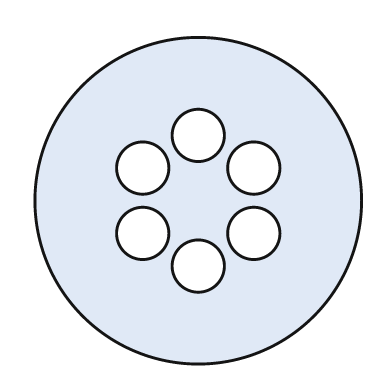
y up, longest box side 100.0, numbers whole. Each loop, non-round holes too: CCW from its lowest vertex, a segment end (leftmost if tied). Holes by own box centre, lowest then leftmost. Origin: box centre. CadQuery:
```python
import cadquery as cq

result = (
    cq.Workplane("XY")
    .moveTo(0.0, 0.0)
    .circle(50.0)
    .moveTo(0.0, -20.0)
    .circle(8.0)
    .moveTo(-17.0, -10.0)
    .circle(8.0)
    .moveTo(17.0, -10.0)
    .circle(8.0)
    .moveTo(-17.0, 10.0)
    .circle(8.0)
    .moveTo(17.0, 10.0)
    .circle(8.0)
    .moveTo(0.0, 20.0)
    .circle(8.0)
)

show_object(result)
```